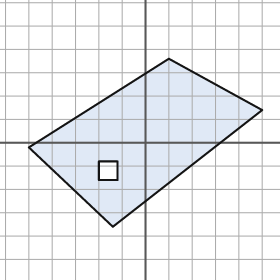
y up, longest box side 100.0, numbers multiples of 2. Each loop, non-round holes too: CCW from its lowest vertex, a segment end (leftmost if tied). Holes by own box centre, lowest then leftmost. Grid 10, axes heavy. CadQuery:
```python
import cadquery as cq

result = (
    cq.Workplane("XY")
    .moveTo(-14.0, -36.0)
    .lineTo(50.0, 14.0)
    .lineTo(10.0, 36.0)
    .lineTo(-50.0, -2.0)
    .close()
    .moveTo(-20.0, -16.0)
    .lineTo(-12.0, -16.0)
    .lineTo(-12.0, -8.0)
    .lineTo(-20.0, -8.0)
    .close()
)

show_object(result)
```